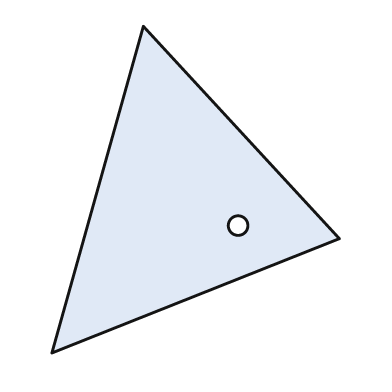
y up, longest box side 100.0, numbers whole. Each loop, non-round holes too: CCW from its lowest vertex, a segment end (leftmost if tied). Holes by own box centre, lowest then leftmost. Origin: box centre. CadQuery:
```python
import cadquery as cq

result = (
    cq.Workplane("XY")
    .moveTo(-44.0, -50.0)
    .lineTo(44.0, -15.0)
    .lineTo(-16.0, 50.0)
    .close()
    .moveTo(13.0, -11.0)
    .circle(3.0)
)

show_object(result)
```